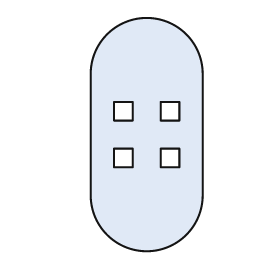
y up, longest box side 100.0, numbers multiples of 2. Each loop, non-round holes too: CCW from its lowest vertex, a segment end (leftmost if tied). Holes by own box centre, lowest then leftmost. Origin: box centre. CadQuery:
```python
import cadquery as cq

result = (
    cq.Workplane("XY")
    .moveTo(-24.0, -26.0)
    .threePointArc((0.0, -50.0), (24.0, -26.0))
    .lineTo(24.0, 26.0)
    .threePointArc((0.0, 50.0), (-24.0, 26.0))
    .close()
    .moveTo(-14.0, -14.0)
    .lineTo(-6.0, -14.0)
    .lineTo(-6.0, -6.0)
    .lineTo(-14.0, -6.0)
    .close()
    .moveTo(6.0, -14.0)
    .lineTo(14.0, -14.0)
    .lineTo(14.0, -6.0)
    .lineTo(6.0, -6.0)
    .close()
    .moveTo(-14.0, 6.0)
    .lineTo(-6.0, 6.0)
    .lineTo(-6.0, 14.0)
    .lineTo(-14.0, 14.0)
    .close()
    .moveTo(6.0, 6.0)
    .lineTo(14.0, 6.0)
    .lineTo(14.0, 14.0)
    .lineTo(6.0, 14.0)
    .close()
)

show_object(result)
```